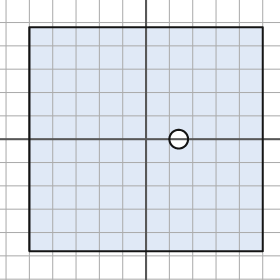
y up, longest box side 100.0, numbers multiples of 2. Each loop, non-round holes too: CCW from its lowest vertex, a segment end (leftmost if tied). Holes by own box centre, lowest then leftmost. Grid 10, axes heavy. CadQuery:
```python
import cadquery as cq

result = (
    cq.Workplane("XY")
    .moveTo(-50.0, -48.0)
    .lineTo(50.0, -48.0)
    .lineTo(50.0, 48.0)
    .lineTo(-50.0, 48.0)
    .close()
    .moveTo(14.0, 0.0)
    .circle(4.0)
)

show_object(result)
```